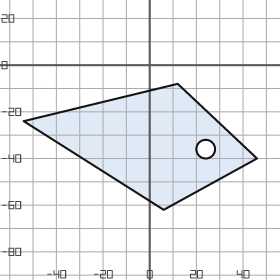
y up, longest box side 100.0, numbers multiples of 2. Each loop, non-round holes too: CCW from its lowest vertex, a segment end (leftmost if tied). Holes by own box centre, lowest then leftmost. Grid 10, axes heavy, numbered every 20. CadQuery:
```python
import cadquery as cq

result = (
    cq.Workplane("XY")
    .moveTo(6.0, -62.0)
    .lineTo(46.0, -40.0)
    .lineTo(12.0, -8.0)
    .lineTo(-54.0, -24.0)
    .close()
    .moveTo(24.0, -36.0)
    .circle(4.0)
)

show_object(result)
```